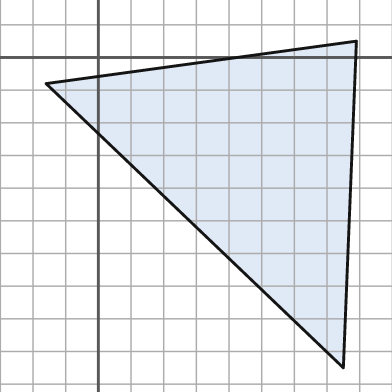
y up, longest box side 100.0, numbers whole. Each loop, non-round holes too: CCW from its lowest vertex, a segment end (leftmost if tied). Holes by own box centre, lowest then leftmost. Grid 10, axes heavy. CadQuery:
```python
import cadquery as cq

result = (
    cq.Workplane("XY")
    .moveTo(75.0, -95.0)
    .lineTo(79.0, 5.0)
    .lineTo(-16.0, -8.0)
    .close()
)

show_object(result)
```